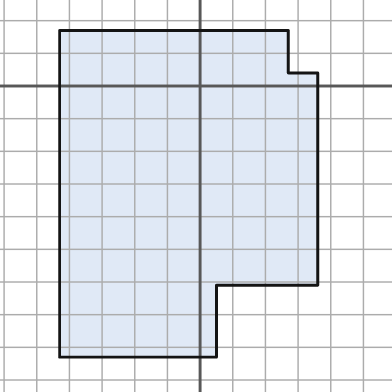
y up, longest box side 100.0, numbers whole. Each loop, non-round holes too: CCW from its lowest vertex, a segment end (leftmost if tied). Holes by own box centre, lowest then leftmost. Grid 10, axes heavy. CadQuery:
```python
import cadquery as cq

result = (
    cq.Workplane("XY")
    .moveTo(-43.0, -83.0)
    .lineTo(5.0, -83.0)
    .lineTo(5.0, -61.0)
    .lineTo(36.0, -61.0)
    .lineTo(36.0, 4.0)
    .lineTo(27.0, 4.0)
    .lineTo(27.0, 17.0)
    .lineTo(-43.0, 17.0)
    .close()
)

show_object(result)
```